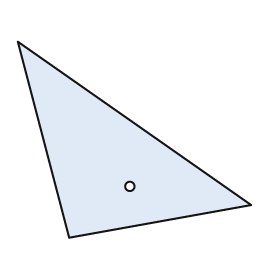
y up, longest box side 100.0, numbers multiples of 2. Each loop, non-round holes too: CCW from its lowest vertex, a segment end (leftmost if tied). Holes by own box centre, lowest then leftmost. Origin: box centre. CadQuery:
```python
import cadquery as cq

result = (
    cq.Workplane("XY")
    .moveTo(-28.0, -42.0)
    .lineTo(50.0, -28.0)
    .lineTo(-50.0, 42.0)
    .close()
    .moveTo(-2.0, -20.0)
    .circle(2.0)
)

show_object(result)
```